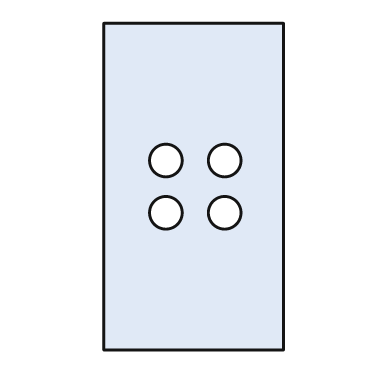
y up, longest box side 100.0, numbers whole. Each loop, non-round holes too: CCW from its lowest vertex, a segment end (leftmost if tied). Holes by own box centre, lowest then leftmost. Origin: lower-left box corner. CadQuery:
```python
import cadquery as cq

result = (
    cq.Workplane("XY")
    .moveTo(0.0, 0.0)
    .lineTo(55.0, 0.0)
    .lineTo(55.0, 100.0)
    .lineTo(0.0, 100.0)
    .close()
    .moveTo(19.0, 42.0)
    .circle(5.0)
    .moveTo(37.0, 42.0)
    .circle(5.0)
    .moveTo(19.0, 58.0)
    .circle(5.0)
    .moveTo(37.0, 58.0)
    .circle(5.0)
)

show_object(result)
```